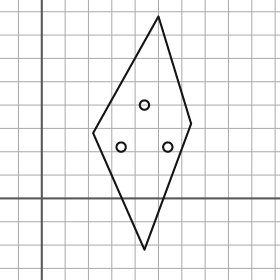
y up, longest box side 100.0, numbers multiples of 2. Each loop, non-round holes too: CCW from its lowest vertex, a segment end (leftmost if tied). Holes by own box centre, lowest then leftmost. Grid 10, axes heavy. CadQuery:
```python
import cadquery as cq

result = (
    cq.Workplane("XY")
    .moveTo(44.0, -22.0)
    .lineTo(64.0, 32.0)
    .lineTo(50.0, 78.0)
    .lineTo(22.0, 28.0)
    .close()
    .moveTo(34.0, 22.0)
    .circle(2.0)
    .moveTo(54.0, 22.0)
    .circle(2.0)
    .moveTo(44.0, 40.0)
    .circle(2.0)
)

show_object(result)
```